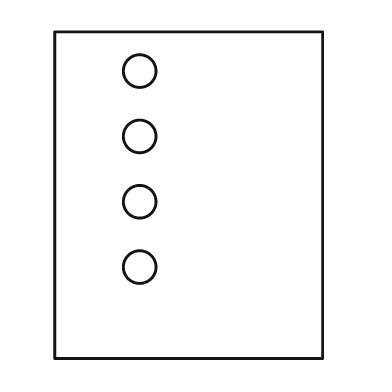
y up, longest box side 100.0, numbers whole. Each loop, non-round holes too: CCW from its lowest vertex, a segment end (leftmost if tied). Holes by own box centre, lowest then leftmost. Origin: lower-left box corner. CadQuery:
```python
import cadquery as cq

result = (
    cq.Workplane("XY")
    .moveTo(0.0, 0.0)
    .lineTo(82.0, 0.0)
    .lineTo(82.0, 100.0)
    .lineTo(0.0, 100.0)
    .close()
    .moveTo(26.0, 28.0)
    .circle(5.0)
    .moveTo(26.0, 48.0)
    .circle(5.0)
    .moveTo(26.0, 68.0)
    .circle(5.0)
    .moveTo(26.0, 88.0)
    .circle(5.0)
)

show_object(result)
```